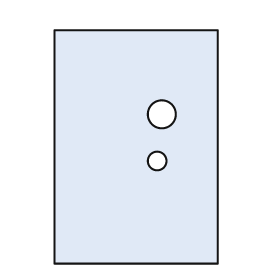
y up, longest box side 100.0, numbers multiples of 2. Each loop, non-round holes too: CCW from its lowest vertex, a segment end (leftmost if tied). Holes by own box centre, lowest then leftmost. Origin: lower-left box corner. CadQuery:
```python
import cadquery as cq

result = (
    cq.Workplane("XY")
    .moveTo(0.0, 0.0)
    .lineTo(70.0, 0.0)
    .lineTo(70.0, 100.0)
    .lineTo(0.0, 100.0)
    .close()
    .moveTo(44.0, 44.0)
    .circle(4.0)
    .moveTo(46.0, 64.0)
    .circle(6.0)
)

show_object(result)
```